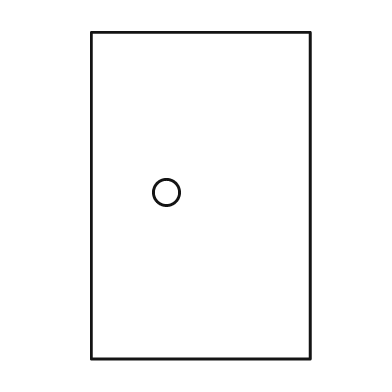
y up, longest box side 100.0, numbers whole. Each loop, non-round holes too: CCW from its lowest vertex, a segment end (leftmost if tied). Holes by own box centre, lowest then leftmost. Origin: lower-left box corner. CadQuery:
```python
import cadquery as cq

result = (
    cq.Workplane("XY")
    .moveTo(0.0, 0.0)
    .lineTo(67.0, 0.0)
    .lineTo(67.0, 100.0)
    .lineTo(0.0, 100.0)
    .close()
    .moveTo(23.0, 51.0)
    .circle(4.0)
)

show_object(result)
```